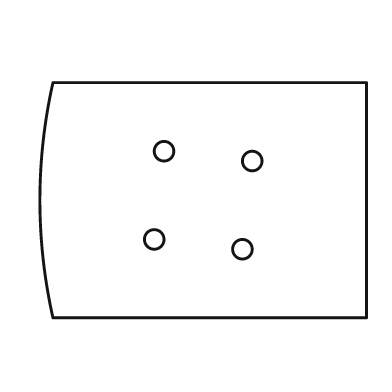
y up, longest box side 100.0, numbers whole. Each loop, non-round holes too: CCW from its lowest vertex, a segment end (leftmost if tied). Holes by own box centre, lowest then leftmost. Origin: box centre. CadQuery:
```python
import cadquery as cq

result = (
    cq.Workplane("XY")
    .moveTo(-46.0, -36.0)
    .lineTo(50.0, -36.0)
    .lineTo(50.0, 36.0)
    .lineTo(-46.0, 36.0)
    .threePointArc((-50.0, 0.0), (-46.0, -36.0))
    .close()
    .moveTo(12.0, -15.0)
    .circle(3.0)
    .moveTo(-15.0, -12.0)
    .circle(3.0)
    .moveTo(15.0, 12.0)
    .circle(3.0)
    .moveTo(-12.0, 15.0)
    .circle(3.0)
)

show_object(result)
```